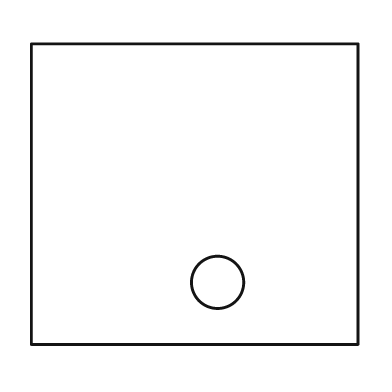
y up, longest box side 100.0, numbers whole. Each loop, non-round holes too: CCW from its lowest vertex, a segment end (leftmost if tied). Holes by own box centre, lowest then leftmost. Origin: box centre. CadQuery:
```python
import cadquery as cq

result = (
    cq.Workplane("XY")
    .moveTo(-50.0, -46.0)
    .lineTo(50.0, -46.0)
    .lineTo(50.0, 46.0)
    .lineTo(-50.0, 46.0)
    .close()
    .moveTo(7.0, -27.0)
    .circle(8.0)
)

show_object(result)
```